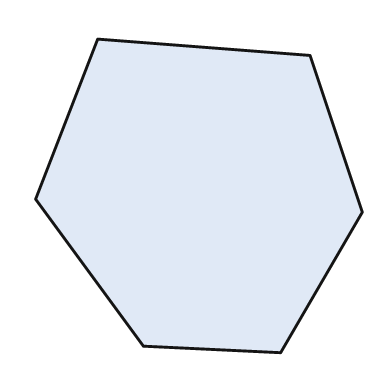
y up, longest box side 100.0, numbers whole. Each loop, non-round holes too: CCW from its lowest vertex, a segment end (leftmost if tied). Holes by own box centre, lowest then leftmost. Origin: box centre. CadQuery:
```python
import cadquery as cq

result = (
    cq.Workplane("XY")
    .moveTo(25.0, -48.0)
    .lineTo(50.0, -5.0)
    .lineTo(34.0, 43.0)
    .lineTo(-31.0, 48.0)
    .lineTo(-50.0, -1.0)
    .lineTo(-17.0, -46.0)
    .close()
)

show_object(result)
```